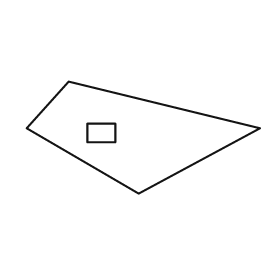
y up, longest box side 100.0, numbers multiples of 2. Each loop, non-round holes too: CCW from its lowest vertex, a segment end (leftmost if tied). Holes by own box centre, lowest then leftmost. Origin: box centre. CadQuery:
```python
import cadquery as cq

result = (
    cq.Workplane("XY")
    .moveTo(-2.0, -24.0)
    .lineTo(50.0, 4.0)
    .lineTo(-32.0, 24.0)
    .lineTo(-50.0, 4.0)
    .close()
    .moveTo(-24.0, -2.0)
    .lineTo(-12.0, -2.0)
    .lineTo(-12.0, 6.0)
    .lineTo(-24.0, 6.0)
    .close()
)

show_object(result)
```